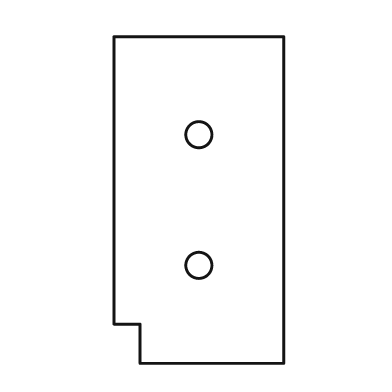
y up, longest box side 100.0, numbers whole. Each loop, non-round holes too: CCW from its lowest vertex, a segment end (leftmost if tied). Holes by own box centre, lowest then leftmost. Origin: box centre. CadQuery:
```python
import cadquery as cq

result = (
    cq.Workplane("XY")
    .moveTo(-18.0, -50.0)
    .lineTo(26.0, -50.0)
    .lineTo(26.0, 50.0)
    .lineTo(-26.0, 50.0)
    .lineTo(-26.0, -38.0)
    .lineTo(-18.0, -38.0)
    .close()
    .moveTo(0.0, -20.0)
    .circle(4.0)
    .moveTo(0.0, 20.0)
    .circle(4.0)
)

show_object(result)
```